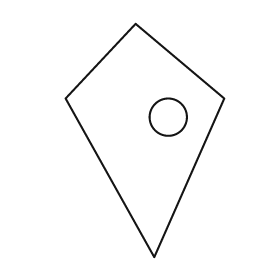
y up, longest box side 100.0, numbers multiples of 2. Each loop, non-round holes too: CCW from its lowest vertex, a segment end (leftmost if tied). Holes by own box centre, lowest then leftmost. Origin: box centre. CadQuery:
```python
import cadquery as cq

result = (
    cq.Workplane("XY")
    .moveTo(4.0, -50.0)
    .lineTo(34.0, 18.0)
    .lineTo(-4.0, 50.0)
    .lineTo(-34.0, 18.0)
    .close()
    .moveTo(10.0, 10.0)
    .circle(8.0)
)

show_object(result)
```